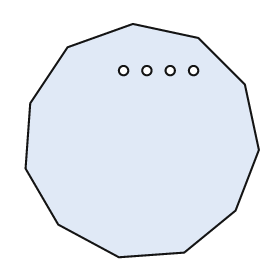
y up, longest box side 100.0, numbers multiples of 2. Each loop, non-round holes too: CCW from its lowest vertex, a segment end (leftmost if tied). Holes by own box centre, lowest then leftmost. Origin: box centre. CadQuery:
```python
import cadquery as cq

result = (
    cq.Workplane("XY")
    .moveTo(-10.0, -50.0)
    .lineTo(18.0, -48.0)
    .lineTo(40.0, -30.0)
    .lineTo(50.0, -4.0)
    .lineTo(44.0, 24.0)
    .lineTo(24.0, 44.0)
    .lineTo(-4.0, 50.0)
    .lineTo(-32.0, 40.0)
    .lineTo(-48.0, 16.0)
    .lineTo(-50.0, -12.0)
    .lineTo(-36.0, -36.0)
    .close()
    .moveTo(-8.0, 30.0)
    .circle(2.0)
    .moveTo(2.0, 30.0)
    .circle(2.0)
    .moveTo(12.0, 30.0)
    .circle(2.0)
    .moveTo(22.0, 30.0)
    .circle(2.0)
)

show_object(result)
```